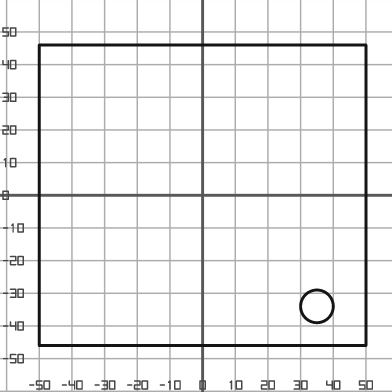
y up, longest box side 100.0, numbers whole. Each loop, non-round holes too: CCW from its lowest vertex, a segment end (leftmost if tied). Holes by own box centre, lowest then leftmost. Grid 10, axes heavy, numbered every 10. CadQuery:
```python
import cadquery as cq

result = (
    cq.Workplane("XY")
    .moveTo(-50.0, -46.0)
    .lineTo(50.0, -46.0)
    .lineTo(50.0, 46.0)
    .lineTo(-50.0, 46.0)
    .close()
    .moveTo(35.0, -34.0)
    .circle(5.0)
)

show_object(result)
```